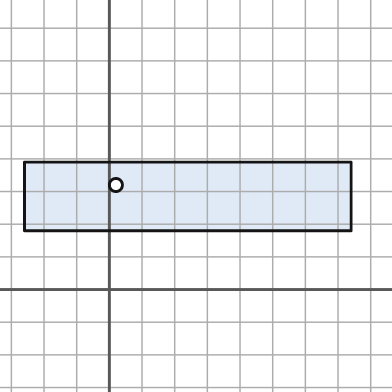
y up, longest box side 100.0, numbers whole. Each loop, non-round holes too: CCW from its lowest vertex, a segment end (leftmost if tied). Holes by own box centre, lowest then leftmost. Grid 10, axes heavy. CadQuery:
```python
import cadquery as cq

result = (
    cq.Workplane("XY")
    .moveTo(-26.0, 18.0)
    .lineTo(74.0, 18.0)
    .lineTo(74.0, 39.0)
    .lineTo(-26.0, 39.0)
    .close()
    .moveTo(2.0, 32.0)
    .circle(2.0)
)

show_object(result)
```